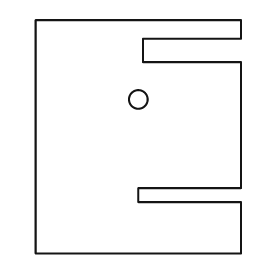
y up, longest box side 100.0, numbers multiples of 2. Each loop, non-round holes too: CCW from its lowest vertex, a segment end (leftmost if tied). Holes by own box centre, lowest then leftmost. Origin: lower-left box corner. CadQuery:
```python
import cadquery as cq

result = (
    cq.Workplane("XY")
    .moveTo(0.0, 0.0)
    .lineTo(88.0, 0.0)
    .lineTo(88.0, 22.0)
    .lineTo(44.0, 22.0)
    .lineTo(44.0, 28.0)
    .lineTo(88.0, 28.0)
    .lineTo(88.0, 82.0)
    .lineTo(46.0, 82.0)
    .lineTo(46.0, 92.0)
    .lineTo(88.0, 92.0)
    .lineTo(88.0, 100.0)
    .lineTo(0.0, 100.0)
    .close()
    .moveTo(44.0, 66.0)
    .circle(4.0)
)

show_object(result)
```